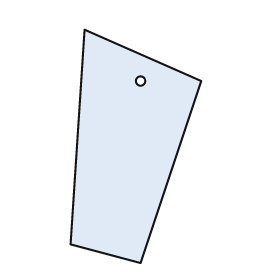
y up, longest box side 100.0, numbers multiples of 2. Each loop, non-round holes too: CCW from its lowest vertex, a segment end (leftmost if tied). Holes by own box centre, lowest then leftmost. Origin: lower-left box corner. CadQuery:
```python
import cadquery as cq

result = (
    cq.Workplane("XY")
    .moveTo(30.0, 0.0)
    .lineTo(56.0, 78.0)
    .lineTo(6.0, 100.0)
    .lineTo(0.0, 8.0)
    .close()
    .moveTo(30.0, 78.0)
    .circle(2.0)
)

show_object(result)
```